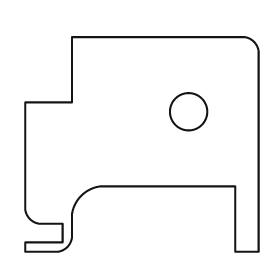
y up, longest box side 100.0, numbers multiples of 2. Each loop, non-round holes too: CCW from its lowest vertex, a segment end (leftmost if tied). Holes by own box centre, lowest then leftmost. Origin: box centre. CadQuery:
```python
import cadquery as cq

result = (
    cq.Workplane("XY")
    .moveTo(-50.0, -46.0)
    .lineTo(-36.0, -46.0)
    .threePointArc((-32.0, -44.0), (-30.0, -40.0))
    .lineTo(-30.0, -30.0)
    .threePointArc((-26.0, -22.0), (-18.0, -18.0))
    .lineTo(40.0, -18.0)
    .lineTo(40.0, -46.0)
    .lineTo(50.0, -46.0)
    .lineTo(50.0, 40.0)
    .threePointArc((48.0, 44.0), (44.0, 46.0))
    .lineTo(-30.0, 46.0)
    .lineTo(-30.0, 18.0)
    .lineTo(-50.0, 18.0)
    .lineTo(-50.0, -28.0)
    .threePointArc((-48.0, -32.0), (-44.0, -34.0))
    .lineTo(-34.0, -34.0)
    .lineTo(-34.0, -42.0)
    .lineTo(-50.0, -42.0)
    .close()
    .moveTo(20.0, 14.0)
    .circle(8.0)
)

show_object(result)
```